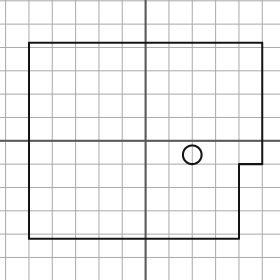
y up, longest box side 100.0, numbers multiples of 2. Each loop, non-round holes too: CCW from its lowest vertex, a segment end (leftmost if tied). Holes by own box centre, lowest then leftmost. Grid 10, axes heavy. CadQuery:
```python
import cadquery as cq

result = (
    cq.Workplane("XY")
    .moveTo(-50.0, -42.0)
    .lineTo(40.0, -42.0)
    .lineTo(40.0, -10.0)
    .lineTo(50.0, -10.0)
    .lineTo(50.0, 42.0)
    .lineTo(-50.0, 42.0)
    .close()
    .moveTo(20.0, -6.0)
    .circle(4.0)
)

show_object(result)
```